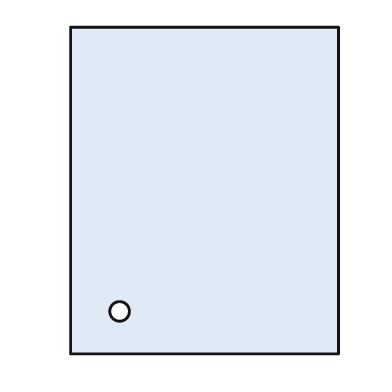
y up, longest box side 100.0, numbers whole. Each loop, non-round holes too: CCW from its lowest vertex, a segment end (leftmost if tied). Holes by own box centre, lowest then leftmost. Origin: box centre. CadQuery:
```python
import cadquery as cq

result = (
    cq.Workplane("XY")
    .moveTo(-41.0, -50.0)
    .lineTo(41.0, -50.0)
    .lineTo(41.0, 50.0)
    .lineTo(-41.0, 50.0)
    .close()
    .moveTo(-26.0, -37.0)
    .circle(3.0)
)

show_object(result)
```